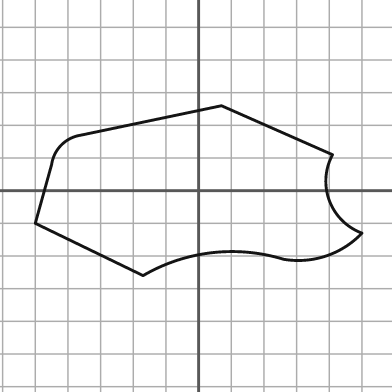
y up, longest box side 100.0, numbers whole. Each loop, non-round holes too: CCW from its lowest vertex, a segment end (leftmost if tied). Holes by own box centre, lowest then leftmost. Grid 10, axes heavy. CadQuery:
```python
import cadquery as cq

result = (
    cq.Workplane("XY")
    .moveTo(-17.0, -26.0)
    .threePointArc((4.0, -19.0), (26.0, -21.0))
    .threePointArc((39.0, -20.0), (50.0, -13.0))
    .threePointArc((40.0, -3.0), (41.0, 11.0))
    .lineTo(7.0, 26.0)
    .lineTo(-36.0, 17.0)
    .threePointArc((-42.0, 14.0), (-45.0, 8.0))
    .lineTo(-50.0, -10.0)
    .close()
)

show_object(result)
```